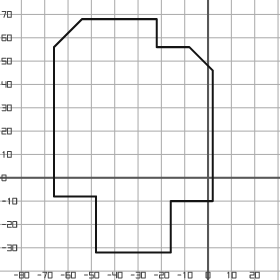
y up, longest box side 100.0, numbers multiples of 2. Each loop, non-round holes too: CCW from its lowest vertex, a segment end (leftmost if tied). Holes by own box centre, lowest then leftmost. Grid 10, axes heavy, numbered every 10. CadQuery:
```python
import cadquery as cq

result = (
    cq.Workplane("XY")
    .moveTo(-48.0, -32.0)
    .lineTo(-16.0, -32.0)
    .lineTo(-16.0, -10.0)
    .lineTo(2.0, -10.0)
    .lineTo(2.0, 46.0)
    .lineTo(-8.0, 56.0)
    .lineTo(-22.0, 56.0)
    .lineTo(-22.0, 68.0)
    .lineTo(-54.0, 68.0)
    .lineTo(-66.0, 56.0)
    .lineTo(-66.0, -8.0)
    .lineTo(-48.0, -8.0)
    .close()
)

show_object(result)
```